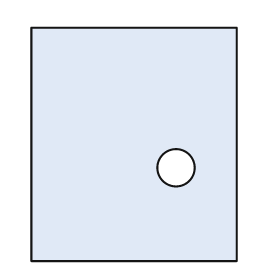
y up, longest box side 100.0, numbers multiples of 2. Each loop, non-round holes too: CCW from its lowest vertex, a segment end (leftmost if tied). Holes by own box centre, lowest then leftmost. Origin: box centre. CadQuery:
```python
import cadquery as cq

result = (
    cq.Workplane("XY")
    .moveTo(-44.0, -50.0)
    .lineTo(44.0, -50.0)
    .lineTo(44.0, 50.0)
    .lineTo(-44.0, 50.0)
    .close()
    .moveTo(18.0, -10.0)
    .circle(8.0)
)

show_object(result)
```